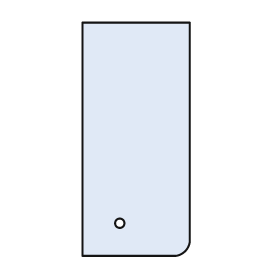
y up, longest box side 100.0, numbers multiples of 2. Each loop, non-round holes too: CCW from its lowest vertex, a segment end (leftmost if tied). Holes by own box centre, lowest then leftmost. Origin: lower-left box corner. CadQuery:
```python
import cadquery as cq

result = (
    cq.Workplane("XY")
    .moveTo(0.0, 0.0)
    .lineTo(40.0, 0.0)
    .threePointArc((44.0, 2.0), (46.0, 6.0))
    .lineTo(46.0, 100.0)
    .lineTo(0.0, 100.0)
    .close()
    .moveTo(16.0, 14.0)
    .circle(2.0)
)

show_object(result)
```